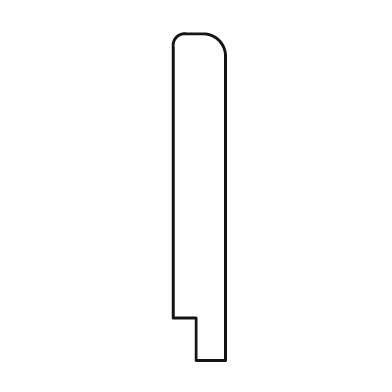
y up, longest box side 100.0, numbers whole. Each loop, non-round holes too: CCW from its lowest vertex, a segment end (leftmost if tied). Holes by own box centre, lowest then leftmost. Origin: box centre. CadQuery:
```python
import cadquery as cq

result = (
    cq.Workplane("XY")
    .moveTo(-1.0, -50.0)
    .lineTo(8.0, -50.0)
    .lineTo(8.0, 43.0)
    .threePointArc((6.0, 48.0), (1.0, 50.0))
    .lineTo(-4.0, 50.0)
    .threePointArc((-7.0, 49.0), (-8.0, 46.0))
    .lineTo(-8.0, -37.0)
    .lineTo(-1.0, -37.0)
    .close()
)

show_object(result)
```